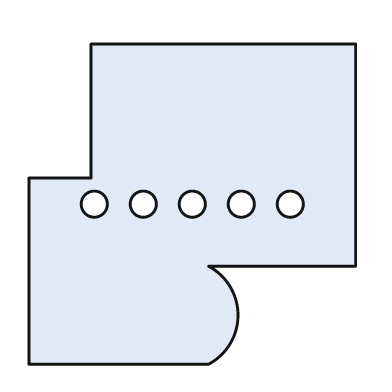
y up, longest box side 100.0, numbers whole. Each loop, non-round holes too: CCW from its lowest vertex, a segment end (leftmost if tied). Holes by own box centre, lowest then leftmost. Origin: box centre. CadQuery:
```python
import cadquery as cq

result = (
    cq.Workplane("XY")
    .moveTo(-50.0, -49.0)
    .lineTo(5.0, -49.0)
    .threePointArc((14.0, -34.0), (5.0, -19.0))
    .lineTo(50.0, -19.0)
    .lineTo(50.0, 49.0)
    .lineTo(-31.0, 49.0)
    .lineTo(-31.0, 8.0)
    .lineTo(-50.0, 8.0)
    .close()
    .moveTo(-30.0, 0.0)
    .circle(4.0)
    .moveTo(-15.0, 0.0)
    .circle(4.0)
    .moveTo(0.0, 0.0)
    .circle(4.0)
    .moveTo(15.0, 0.0)
    .circle(4.0)
    .moveTo(30.0, 0.0)
    .circle(4.0)
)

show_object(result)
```